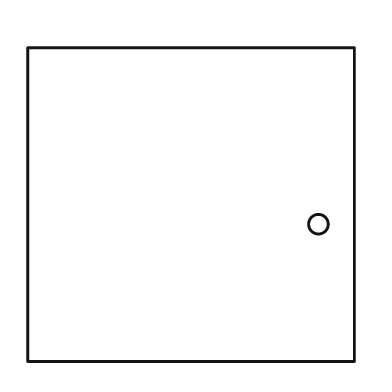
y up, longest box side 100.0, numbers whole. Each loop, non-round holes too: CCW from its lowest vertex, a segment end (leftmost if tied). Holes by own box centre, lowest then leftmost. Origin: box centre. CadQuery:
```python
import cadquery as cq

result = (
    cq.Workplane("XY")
    .moveTo(-50.0, -48.0)
    .lineTo(50.0, -48.0)
    .lineTo(50.0, 48.0)
    .lineTo(-50.0, 48.0)
    .close()
    .moveTo(39.0, -6.0)
    .circle(3.0)
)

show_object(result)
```